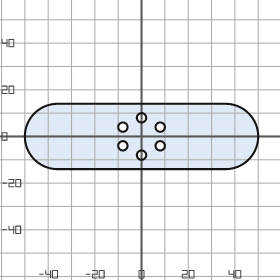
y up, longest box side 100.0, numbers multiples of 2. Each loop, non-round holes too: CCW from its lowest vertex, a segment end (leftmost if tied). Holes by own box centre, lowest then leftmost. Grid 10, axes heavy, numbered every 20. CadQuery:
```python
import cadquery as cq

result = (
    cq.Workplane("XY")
    .moveTo(-36.0, -14.0)
    .lineTo(36.0, -14.0)
    .threePointArc((50.0, 0.0), (36.0, 14.0))
    .lineTo(-36.0, 14.0)
    .threePointArc((-50.0, 0.0), (-36.0, -14.0))
    .close()
    .moveTo(0.0, -8.0)
    .circle(2.0)
    .moveTo(-8.0, -4.0)
    .circle(2.0)
    .moveTo(8.0, -4.0)
    .circle(2.0)
    .moveTo(-8.0, 4.0)
    .circle(2.0)
    .moveTo(8.0, 4.0)
    .circle(2.0)
    .moveTo(0.0, 8.0)
    .circle(2.0)
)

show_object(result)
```